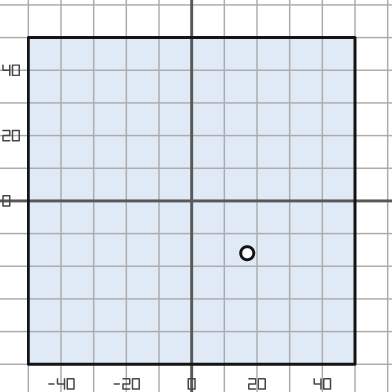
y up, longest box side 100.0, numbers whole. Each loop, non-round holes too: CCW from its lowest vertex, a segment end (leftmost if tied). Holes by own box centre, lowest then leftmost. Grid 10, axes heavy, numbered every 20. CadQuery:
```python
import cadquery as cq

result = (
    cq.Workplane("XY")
    .moveTo(-50.0, -50.0)
    .lineTo(50.0, -50.0)
    .lineTo(50.0, 50.0)
    .lineTo(-50.0, 50.0)
    .close()
    .moveTo(17.0, -16.0)
    .circle(2.0)
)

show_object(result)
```